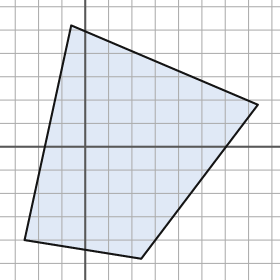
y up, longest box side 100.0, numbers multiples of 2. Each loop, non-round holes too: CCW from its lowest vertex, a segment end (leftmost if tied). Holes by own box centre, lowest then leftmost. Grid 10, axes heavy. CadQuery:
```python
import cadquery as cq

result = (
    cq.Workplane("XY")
    .moveTo(24.0, -48.0)
    .lineTo(74.0, 18.0)
    .lineTo(-6.0, 52.0)
    .lineTo(-26.0, -40.0)
    .close()
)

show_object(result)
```